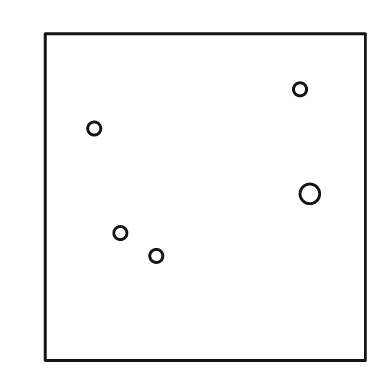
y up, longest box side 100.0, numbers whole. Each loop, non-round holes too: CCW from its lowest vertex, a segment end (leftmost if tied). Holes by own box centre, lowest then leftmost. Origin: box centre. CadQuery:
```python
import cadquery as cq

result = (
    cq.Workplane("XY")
    .moveTo(-49.0, -50.0)
    .lineTo(49.0, -50.0)
    .lineTo(49.0, 50.0)
    .lineTo(-49.0, 50.0)
    .close()
    .moveTo(-15.0, -18.0)
    .circle(2.0)
    .moveTo(-26.0, -11.0)
    .circle(2.0)
    .moveTo(32.0, 1.0)
    .circle(3.0)
    .moveTo(-34.0, 21.0)
    .circle(2.0)
    .moveTo(29.0, 33.0)
    .circle(2.0)
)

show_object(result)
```